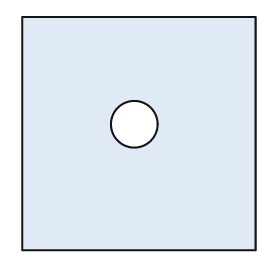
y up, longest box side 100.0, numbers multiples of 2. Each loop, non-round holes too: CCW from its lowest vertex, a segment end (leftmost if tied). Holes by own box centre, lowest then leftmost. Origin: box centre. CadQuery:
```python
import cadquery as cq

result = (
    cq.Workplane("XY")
    .moveTo(-50.0, -50.0)
    .lineTo(50.0, -50.0)
    .lineTo(50.0, 50.0)
    .lineTo(-50.0, 50.0)
    .close()
    .moveTo(-2.0, 4.0)
    .circle(10.0)
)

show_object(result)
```